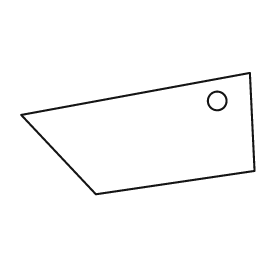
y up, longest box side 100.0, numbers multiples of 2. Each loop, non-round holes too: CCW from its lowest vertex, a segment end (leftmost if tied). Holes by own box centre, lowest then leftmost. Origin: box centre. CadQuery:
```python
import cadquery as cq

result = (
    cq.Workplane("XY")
    .moveTo(-18.0, -26.0)
    .lineTo(50.0, -16.0)
    .lineTo(48.0, 26.0)
    .lineTo(-50.0, 8.0)
    .close()
    .moveTo(34.0, 14.0)
    .circle(4.0)
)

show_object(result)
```